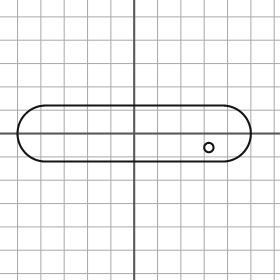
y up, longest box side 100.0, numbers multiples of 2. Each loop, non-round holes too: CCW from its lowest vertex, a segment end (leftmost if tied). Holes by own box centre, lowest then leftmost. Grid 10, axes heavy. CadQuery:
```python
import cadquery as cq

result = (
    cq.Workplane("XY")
    .moveTo(-38.0, -12.0)
    .lineTo(38.0, -12.0)
    .threePointArc((50.0, 0.0), (38.0, 12.0))
    .lineTo(-38.0, 12.0)
    .threePointArc((-50.0, 0.0), (-38.0, -12.0))
    .close()
    .moveTo(32.0, -6.0)
    .circle(2.0)
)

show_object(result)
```